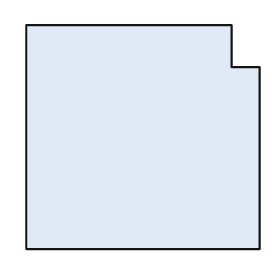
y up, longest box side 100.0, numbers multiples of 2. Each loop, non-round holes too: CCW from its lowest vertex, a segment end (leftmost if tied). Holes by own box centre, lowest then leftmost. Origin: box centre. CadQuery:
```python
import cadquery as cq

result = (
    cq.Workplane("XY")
    .moveTo(-50.0, -48.0)
    .lineTo(50.0, -48.0)
    .lineTo(50.0, 30.0)
    .lineTo(38.0, 30.0)
    .lineTo(38.0, 48.0)
    .lineTo(-50.0, 48.0)
    .close()
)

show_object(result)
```